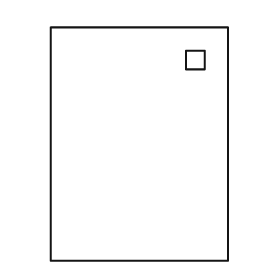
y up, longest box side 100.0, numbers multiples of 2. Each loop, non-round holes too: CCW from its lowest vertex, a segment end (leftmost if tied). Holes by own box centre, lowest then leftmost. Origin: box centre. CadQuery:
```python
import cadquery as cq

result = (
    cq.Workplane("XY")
    .moveTo(-38.0, -50.0)
    .lineTo(38.0, -50.0)
    .lineTo(38.0, 50.0)
    .lineTo(-38.0, 50.0)
    .close()
    .moveTo(20.0, 32.0)
    .lineTo(28.0, 32.0)
    .lineTo(28.0, 40.0)
    .lineTo(20.0, 40.0)
    .close()
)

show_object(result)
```